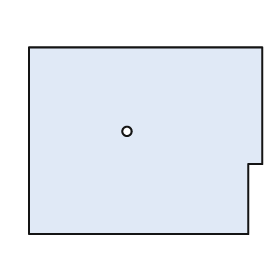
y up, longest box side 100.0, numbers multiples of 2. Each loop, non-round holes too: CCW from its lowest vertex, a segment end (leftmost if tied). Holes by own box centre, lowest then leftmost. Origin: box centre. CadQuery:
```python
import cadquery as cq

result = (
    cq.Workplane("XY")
    .moveTo(-50.0, -40.0)
    .lineTo(44.0, -40.0)
    .lineTo(44.0, -10.0)
    .lineTo(50.0, -10.0)
    .lineTo(50.0, 40.0)
    .lineTo(-50.0, 40.0)
    .close()
    .moveTo(-8.0, 4.0)
    .circle(2.0)
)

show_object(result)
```